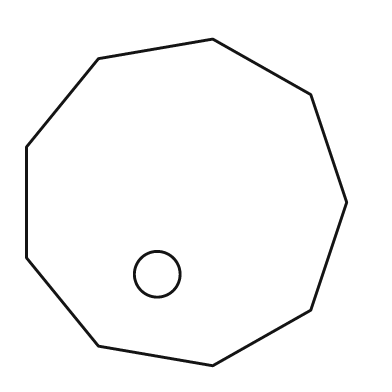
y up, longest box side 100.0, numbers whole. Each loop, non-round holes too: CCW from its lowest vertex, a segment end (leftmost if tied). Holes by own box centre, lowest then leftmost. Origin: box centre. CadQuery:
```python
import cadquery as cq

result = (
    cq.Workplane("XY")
    .moveTo(8.0, -50.0)
    .lineTo(38.0, -33.0)
    .lineTo(49.0, 0.0)
    .lineTo(38.0, 33.0)
    .lineTo(8.0, 50.0)
    .lineTo(-27.0, 44.0)
    .lineTo(-49.0, 17.0)
    .lineTo(-49.0, -17.0)
    .lineTo(-27.0, -44.0)
    .close()
    .moveTo(-9.0, -22.0)
    .circle(7.0)
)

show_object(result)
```